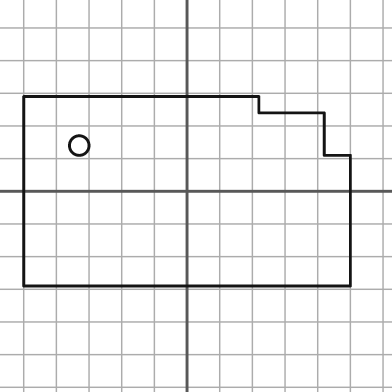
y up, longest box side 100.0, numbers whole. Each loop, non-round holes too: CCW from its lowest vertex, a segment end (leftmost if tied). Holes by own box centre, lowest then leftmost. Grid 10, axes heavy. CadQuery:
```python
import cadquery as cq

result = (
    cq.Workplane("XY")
    .moveTo(-50.0, -29.0)
    .lineTo(50.0, -29.0)
    .lineTo(50.0, 11.0)
    .lineTo(42.0, 11.0)
    .lineTo(42.0, 24.0)
    .lineTo(22.0, 24.0)
    .lineTo(22.0, 29.0)
    .lineTo(-50.0, 29.0)
    .close()
    .moveTo(-33.0, 14.0)
    .circle(3.0)
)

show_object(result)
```